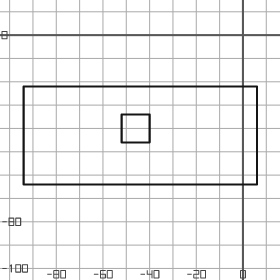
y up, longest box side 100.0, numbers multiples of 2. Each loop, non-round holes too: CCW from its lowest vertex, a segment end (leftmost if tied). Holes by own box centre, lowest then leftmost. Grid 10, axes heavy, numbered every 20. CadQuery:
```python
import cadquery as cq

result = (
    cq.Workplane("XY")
    .moveTo(-94.0, -64.0)
    .lineTo(6.0, -64.0)
    .lineTo(6.0, -22.0)
    .lineTo(-94.0, -22.0)
    .close()
    .moveTo(-52.0, -46.0)
    .lineTo(-40.0, -46.0)
    .lineTo(-40.0, -34.0)
    .lineTo(-52.0, -34.0)
    .close()
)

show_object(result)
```